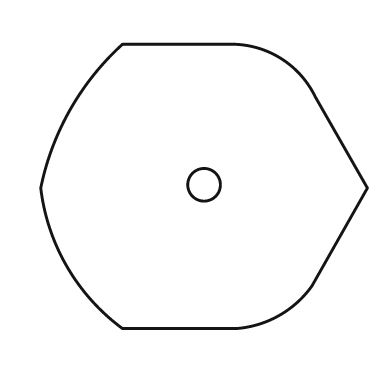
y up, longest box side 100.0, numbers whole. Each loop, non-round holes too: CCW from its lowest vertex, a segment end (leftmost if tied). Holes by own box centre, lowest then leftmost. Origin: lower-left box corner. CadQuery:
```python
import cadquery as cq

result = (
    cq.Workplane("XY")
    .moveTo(25.0, 0.0)
    .lineTo(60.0, 0.0)
    .threePointArc((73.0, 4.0), (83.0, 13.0))
    .lineTo(100.0, 43.0)
    .lineTo(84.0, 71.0)
    .threePointArc((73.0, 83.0), (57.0, 87.0))
    .lineTo(25.0, 87.0)
    .threePointArc((9.0, 67.0), (0.0, 43.0))
    .threePointArc((8.0, 19.0), (25.0, 0.0))
    .close()
    .moveTo(50.0, 44.0)
    .circle(5.0)
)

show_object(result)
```